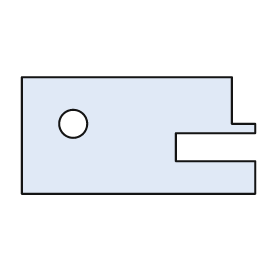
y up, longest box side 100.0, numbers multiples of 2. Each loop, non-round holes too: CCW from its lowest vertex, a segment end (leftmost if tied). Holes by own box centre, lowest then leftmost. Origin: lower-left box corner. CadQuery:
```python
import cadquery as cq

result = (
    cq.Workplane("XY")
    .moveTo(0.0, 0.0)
    .lineTo(100.0, 0.0)
    .lineTo(100.0, 14.0)
    .lineTo(66.0, 14.0)
    .lineTo(66.0, 26.0)
    .lineTo(100.0, 26.0)
    .lineTo(100.0, 30.0)
    .lineTo(90.0, 30.0)
    .lineTo(90.0, 50.0)
    .lineTo(0.0, 50.0)
    .close()
    .moveTo(22.0, 30.0)
    .circle(6.0)
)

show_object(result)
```